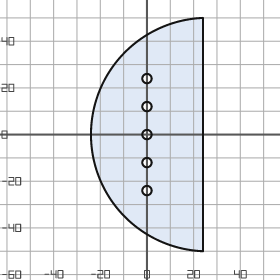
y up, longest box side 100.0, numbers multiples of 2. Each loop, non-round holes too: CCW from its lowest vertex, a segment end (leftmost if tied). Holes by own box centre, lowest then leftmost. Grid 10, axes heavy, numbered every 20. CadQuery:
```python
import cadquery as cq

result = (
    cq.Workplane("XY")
    .moveTo(24.0, -50.0)
    .lineTo(24.0, 50.0)
    .threePointArc((-24.0, 0.0), (24.0, -50.0))
    .close()
    .moveTo(0.0, -24.0)
    .circle(2.0)
    .moveTo(0.0, -12.0)
    .circle(2.0)
    .moveTo(0.0, 0.0)
    .circle(2.0)
    .moveTo(0.0, 12.0)
    .circle(2.0)
    .moveTo(0.0, 24.0)
    .circle(2.0)
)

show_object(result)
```